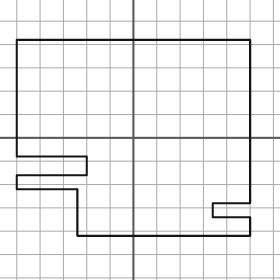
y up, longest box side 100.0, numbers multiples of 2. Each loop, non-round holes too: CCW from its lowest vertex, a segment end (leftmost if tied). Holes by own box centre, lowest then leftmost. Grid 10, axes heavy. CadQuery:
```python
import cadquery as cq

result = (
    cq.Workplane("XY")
    .moveTo(-24.0, -42.0)
    .lineTo(50.0, -42.0)
    .lineTo(50.0, -34.0)
    .lineTo(34.0, -34.0)
    .lineTo(34.0, -28.0)
    .lineTo(50.0, -28.0)
    .lineTo(50.0, 42.0)
    .lineTo(-50.0, 42.0)
    .lineTo(-50.0, -8.0)
    .lineTo(-20.0, -8.0)
    .lineTo(-20.0, -16.0)
    .lineTo(-50.0, -16.0)
    .lineTo(-50.0, -22.0)
    .lineTo(-24.0, -22.0)
    .close()
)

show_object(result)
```